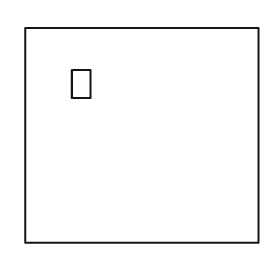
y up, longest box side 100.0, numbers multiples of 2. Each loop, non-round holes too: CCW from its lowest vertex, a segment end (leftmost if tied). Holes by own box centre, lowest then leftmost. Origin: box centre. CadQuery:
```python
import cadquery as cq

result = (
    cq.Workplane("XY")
    .moveTo(-50.0, -46.0)
    .lineTo(50.0, -46.0)
    .lineTo(50.0, 46.0)
    .lineTo(-50.0, 46.0)
    .close()
    .moveTo(-30.0, 16.0)
    .lineTo(-22.0, 16.0)
    .lineTo(-22.0, 28.0)
    .lineTo(-30.0, 28.0)
    .close()
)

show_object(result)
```